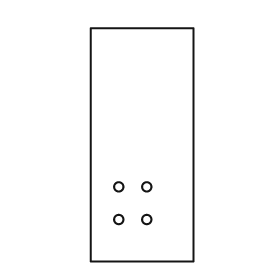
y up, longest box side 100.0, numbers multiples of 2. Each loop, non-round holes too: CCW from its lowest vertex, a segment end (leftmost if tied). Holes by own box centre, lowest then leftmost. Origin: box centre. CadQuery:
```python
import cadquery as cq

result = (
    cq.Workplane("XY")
    .moveTo(-22.0, -50.0)
    .lineTo(22.0, -50.0)
    .lineTo(22.0, 50.0)
    .lineTo(-22.0, 50.0)
    .close()
    .moveTo(-10.0, -32.0)
    .circle(2.0)
    .moveTo(2.0, -32.0)
    .circle(2.0)
    .moveTo(-10.0, -18.0)
    .circle(2.0)
    .moveTo(2.0, -18.0)
    .circle(2.0)
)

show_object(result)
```